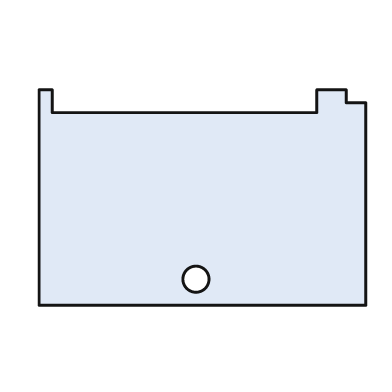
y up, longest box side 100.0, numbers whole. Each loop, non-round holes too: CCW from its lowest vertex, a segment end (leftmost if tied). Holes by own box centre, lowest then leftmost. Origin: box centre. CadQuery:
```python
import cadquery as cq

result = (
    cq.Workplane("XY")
    .moveTo(-50.0, -33.0)
    .lineTo(50.0, -33.0)
    .lineTo(50.0, 29.0)
    .lineTo(44.0, 29.0)
    .lineTo(44.0, 33.0)
    .lineTo(35.0, 33.0)
    .lineTo(35.0, 26.0)
    .lineTo(-46.0, 26.0)
    .lineTo(-46.0, 33.0)
    .lineTo(-50.0, 33.0)
    .close()
    .moveTo(-2.0, -25.0)
    .circle(4.0)
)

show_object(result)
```